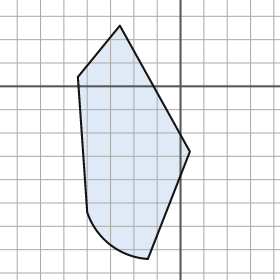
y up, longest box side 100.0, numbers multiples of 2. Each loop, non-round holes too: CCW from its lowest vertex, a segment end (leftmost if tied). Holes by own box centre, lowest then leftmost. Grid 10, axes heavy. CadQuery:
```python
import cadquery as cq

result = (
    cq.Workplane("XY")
    .moveTo(-14.0, -74.0)
    .lineTo(4.0, -28.0)
    .lineTo(-26.0, 26.0)
    .lineTo(-44.0, 4.0)
    .lineTo(-40.0, -54.0)
    .threePointArc((-30.0, -68.0), (-14.0, -74.0))
    .close()
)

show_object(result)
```